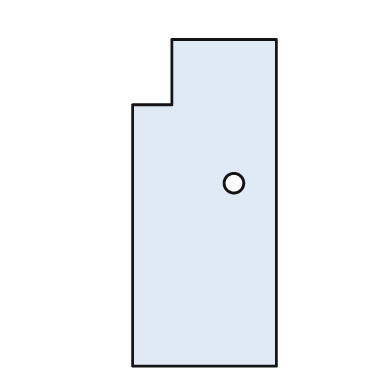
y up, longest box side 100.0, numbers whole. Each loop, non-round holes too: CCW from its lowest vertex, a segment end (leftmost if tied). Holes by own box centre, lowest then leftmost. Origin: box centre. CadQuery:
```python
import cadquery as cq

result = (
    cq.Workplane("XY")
    .moveTo(-22.0, -50.0)
    .lineTo(22.0, -50.0)
    .lineTo(22.0, 50.0)
    .lineTo(-10.0, 50.0)
    .lineTo(-10.0, 30.0)
    .lineTo(-22.0, 30.0)
    .close()
    .moveTo(9.0, 6.0)
    .circle(3.0)
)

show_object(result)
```